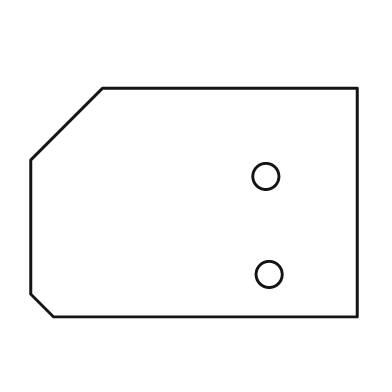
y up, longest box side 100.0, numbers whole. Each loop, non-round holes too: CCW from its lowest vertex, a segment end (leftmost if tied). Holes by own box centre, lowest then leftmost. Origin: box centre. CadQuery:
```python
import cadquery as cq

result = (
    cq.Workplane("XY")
    .moveTo(-43.0, -35.0)
    .lineTo(50.0, -35.0)
    .lineTo(50.0, 35.0)
    .lineTo(-28.0, 35.0)
    .lineTo(-50.0, 13.0)
    .lineTo(-50.0, -28.0)
    .close()
    .moveTo(23.0, -22.0)
    .circle(4.0)
    .moveTo(22.0, 8.0)
    .circle(4.0)
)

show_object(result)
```